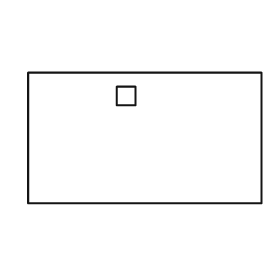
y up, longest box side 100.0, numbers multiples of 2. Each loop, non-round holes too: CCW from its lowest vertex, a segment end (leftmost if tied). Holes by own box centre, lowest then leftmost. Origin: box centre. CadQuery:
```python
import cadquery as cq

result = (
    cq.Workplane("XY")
    .moveTo(-50.0, -28.0)
    .lineTo(50.0, -28.0)
    .lineTo(50.0, 28.0)
    .lineTo(-50.0, 28.0)
    .close()
    .moveTo(-12.0, 14.0)
    .lineTo(-4.0, 14.0)
    .lineTo(-4.0, 22.0)
    .lineTo(-12.0, 22.0)
    .close()
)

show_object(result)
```